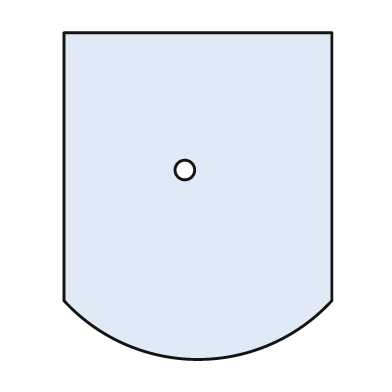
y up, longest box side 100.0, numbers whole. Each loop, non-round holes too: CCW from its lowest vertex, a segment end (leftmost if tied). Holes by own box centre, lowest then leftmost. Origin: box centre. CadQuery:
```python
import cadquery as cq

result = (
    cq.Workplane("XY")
    .moveTo(-41.0, -32.0)
    .threePointArc((0.0, -50.0), (41.0, -32.0))
    .lineTo(41.0, 50.0)
    .lineTo(-41.0, 50.0)
    .close()
    .moveTo(-4.0, 8.0)
    .circle(3.0)
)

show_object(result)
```